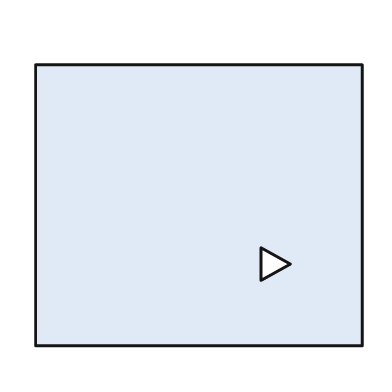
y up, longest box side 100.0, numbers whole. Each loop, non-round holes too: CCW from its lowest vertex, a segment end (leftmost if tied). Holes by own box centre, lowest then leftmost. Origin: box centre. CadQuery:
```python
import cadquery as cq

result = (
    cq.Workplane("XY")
    .moveTo(-50.0, -43.0)
    .lineTo(50.0, -43.0)
    .lineTo(50.0, 43.0)
    .lineTo(-50.0, 43.0)
    .close()
    .moveTo(19.0, -23.0)
    .lineTo(28.0, -18.0)
    .lineTo(19.0, -13.0)
    .close()
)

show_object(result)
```